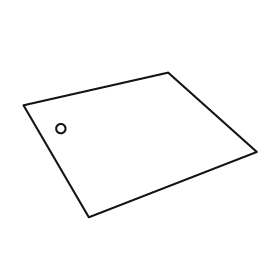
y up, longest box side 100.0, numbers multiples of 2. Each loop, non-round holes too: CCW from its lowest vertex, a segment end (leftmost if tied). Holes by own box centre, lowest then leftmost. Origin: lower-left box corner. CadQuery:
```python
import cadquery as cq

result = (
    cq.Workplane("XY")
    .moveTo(28.0, 0.0)
    .lineTo(100.0, 28.0)
    .lineTo(62.0, 62.0)
    .lineTo(0.0, 48.0)
    .close()
    .moveTo(16.0, 38.0)
    .circle(2.0)
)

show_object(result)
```